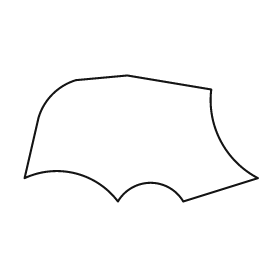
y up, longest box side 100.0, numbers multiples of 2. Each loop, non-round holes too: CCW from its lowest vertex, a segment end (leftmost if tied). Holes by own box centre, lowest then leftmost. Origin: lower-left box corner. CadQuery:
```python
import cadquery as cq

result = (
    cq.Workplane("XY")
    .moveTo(40.0, 0.0)
    .threePointArc((54.0, 8.0), (68.0, 0.0))
    .lineTo(100.0, 10.0)
    .threePointArc((84.0, 26.0), (80.0, 48.0))
    .lineTo(44.0, 54.0)
    .lineTo(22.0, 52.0)
    .threePointArc((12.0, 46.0), (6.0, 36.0))
    .lineTo(0.0, 10.0)
    .threePointArc((22.0, 12.0), (40.0, 0.0))
    .close()
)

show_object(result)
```